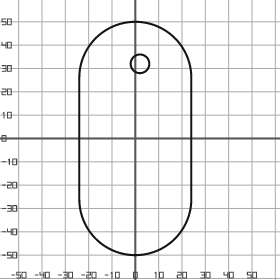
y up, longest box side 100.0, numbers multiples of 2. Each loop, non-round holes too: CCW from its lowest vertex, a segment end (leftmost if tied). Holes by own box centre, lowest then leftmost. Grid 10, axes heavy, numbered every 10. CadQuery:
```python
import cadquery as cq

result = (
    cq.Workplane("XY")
    .moveTo(-24.0, -26.0)
    .threePointArc((0.0, -50.0), (24.0, -26.0))
    .lineTo(24.0, 26.0)
    .threePointArc((0.0, 50.0), (-24.0, 26.0))
    .close()
    .moveTo(2.0, 32.0)
    .circle(4.0)
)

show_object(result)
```